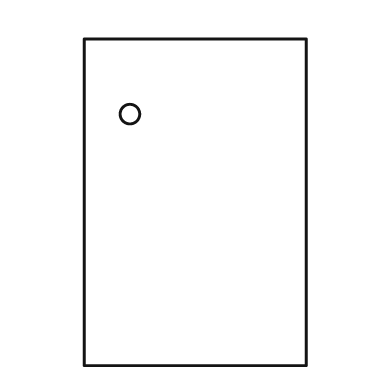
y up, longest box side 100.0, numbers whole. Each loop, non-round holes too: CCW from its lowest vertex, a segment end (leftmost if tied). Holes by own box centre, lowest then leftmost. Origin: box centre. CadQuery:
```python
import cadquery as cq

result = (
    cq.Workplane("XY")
    .moveTo(-34.0, -50.0)
    .lineTo(34.0, -50.0)
    .lineTo(34.0, 50.0)
    .lineTo(-34.0, 50.0)
    .close()
    .moveTo(-20.0, 27.0)
    .circle(3.0)
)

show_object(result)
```